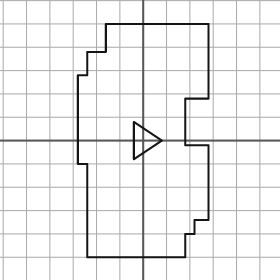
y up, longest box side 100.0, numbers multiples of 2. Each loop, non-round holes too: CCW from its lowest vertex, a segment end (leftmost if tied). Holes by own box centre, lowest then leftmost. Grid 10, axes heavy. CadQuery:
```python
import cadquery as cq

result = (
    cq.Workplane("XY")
    .moveTo(-24.0, -50.0)
    .lineTo(18.0, -50.0)
    .lineTo(18.0, -40.0)
    .lineTo(22.0, -40.0)
    .lineTo(22.0, -34.0)
    .lineTo(28.0, -34.0)
    .lineTo(28.0, -2.0)
    .lineTo(18.0, -2.0)
    .lineTo(18.0, 18.0)
    .lineTo(28.0, 18.0)
    .lineTo(28.0, 50.0)
    .lineTo(-16.0, 50.0)
    .lineTo(-16.0, 38.0)
    .lineTo(-24.0, 38.0)
    .lineTo(-24.0, 28.0)
    .lineTo(-28.0, 28.0)
    .lineTo(-28.0, -10.0)
    .lineTo(-24.0, -10.0)
    .close()
    .moveTo(-4.0, -8.0)
    .lineTo(8.0, 0.0)
    .lineTo(-4.0, 8.0)
    .close()
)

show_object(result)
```